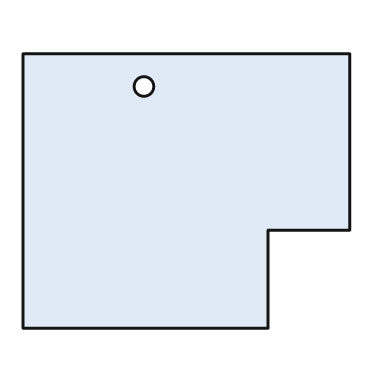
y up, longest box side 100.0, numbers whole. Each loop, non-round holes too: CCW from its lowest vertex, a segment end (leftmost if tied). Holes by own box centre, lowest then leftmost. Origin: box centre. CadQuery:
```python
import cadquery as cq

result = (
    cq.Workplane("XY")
    .moveTo(-50.0, -42.0)
    .lineTo(25.0, -42.0)
    .lineTo(25.0, -12.0)
    .lineTo(50.0, -12.0)
    .lineTo(50.0, 42.0)
    .lineTo(-50.0, 42.0)
    .close()
    .moveTo(-13.0, 32.0)
    .circle(3.0)
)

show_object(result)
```